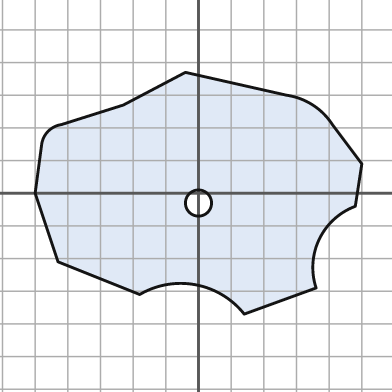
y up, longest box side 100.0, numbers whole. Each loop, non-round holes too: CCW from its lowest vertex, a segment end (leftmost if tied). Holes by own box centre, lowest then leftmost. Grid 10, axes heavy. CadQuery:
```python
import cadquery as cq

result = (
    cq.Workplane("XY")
    .moveTo(14.0, -37.0)
    .lineTo(36.0, -29.0)
    .threePointArc((37.0, -14.0), (48.0, -4.0))
    .lineTo(50.0, 9.0)
    .lineTo(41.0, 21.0)
    .threePointArc((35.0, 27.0), (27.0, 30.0))
    .lineTo(-4.0, 37.0)
    .lineTo(-23.0, 27.0)
    .lineTo(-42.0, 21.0)
    .threePointArc((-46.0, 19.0), (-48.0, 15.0))
    .lineTo(-50.0, 0.0)
    .lineTo(-43.0, -21.0)
    .lineTo(-18.0, -31.0)
    .threePointArc((-1.0, -28.0), (14.0, -37.0))
    .close()
    .moveTo(0.0, -3.0)
    .circle(4.0)
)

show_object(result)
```